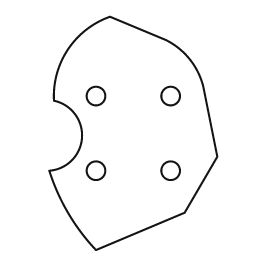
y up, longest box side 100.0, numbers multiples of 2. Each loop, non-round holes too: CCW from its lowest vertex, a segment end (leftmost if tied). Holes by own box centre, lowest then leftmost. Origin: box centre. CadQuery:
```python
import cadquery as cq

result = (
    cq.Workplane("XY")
    .moveTo(-16.0, -50.0)
    .lineTo(22.0, -34.0)
    .lineTo(36.0, -10.0)
    .lineTo(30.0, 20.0)
    .threePointArc((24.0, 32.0), (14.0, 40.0))
    .lineTo(-10.0, 50.0)
    .threePointArc((-28.0, 36.0), (-34.0, 14.0))
    .threePointArc((-22.0, -2.0), (-36.0, -16.0))
    .threePointArc((-28.0, -34.0), (-16.0, -50.0))
    .close()
    .moveTo(-16.0, -16.0)
    .circle(4.0)
    .moveTo(16.0, -16.0)
    .circle(4.0)
    .moveTo(-16.0, 16.0)
    .circle(4.0)
    .moveTo(16.0, 16.0)
    .circle(4.0)
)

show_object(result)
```